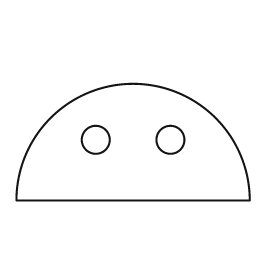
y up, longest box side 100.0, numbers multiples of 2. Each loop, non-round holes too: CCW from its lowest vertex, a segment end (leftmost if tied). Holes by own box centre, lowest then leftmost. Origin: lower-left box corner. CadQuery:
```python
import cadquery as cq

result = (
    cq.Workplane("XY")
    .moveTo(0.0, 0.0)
    .lineTo(100.0, 0.0)
    .threePointArc((50.0, 50.0), (0.0, 0.0))
    .close()
    .moveTo(34.0, 26.0)
    .circle(6.0)
    .moveTo(66.0, 26.0)
    .circle(6.0)
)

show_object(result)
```